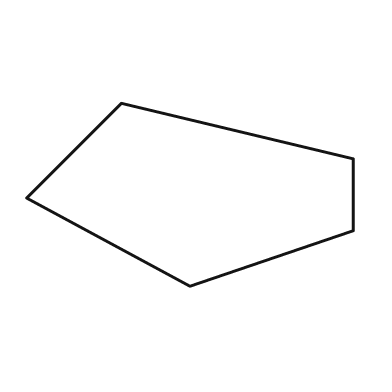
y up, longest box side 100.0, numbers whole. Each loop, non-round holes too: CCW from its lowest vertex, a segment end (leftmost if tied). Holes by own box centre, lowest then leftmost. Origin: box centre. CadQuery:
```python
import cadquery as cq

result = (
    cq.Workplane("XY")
    .moveTo(0.0, -28.0)
    .lineTo(50.0, -11.0)
    .lineTo(50.0, 11.0)
    .lineTo(-21.0, 28.0)
    .lineTo(-50.0, -1.0)
    .close()
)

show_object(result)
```